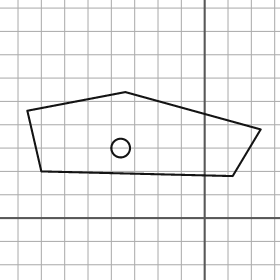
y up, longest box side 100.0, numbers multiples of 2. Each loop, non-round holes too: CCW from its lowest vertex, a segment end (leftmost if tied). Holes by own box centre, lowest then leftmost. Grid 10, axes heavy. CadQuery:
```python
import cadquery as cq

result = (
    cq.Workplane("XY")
    .moveTo(12.0, 18.0)
    .lineTo(24.0, 38.0)
    .lineTo(-34.0, 54.0)
    .lineTo(-76.0, 46.0)
    .lineTo(-70.0, 20.0)
    .close()
    .moveTo(-36.0, 30.0)
    .circle(4.0)
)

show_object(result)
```